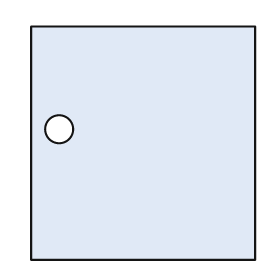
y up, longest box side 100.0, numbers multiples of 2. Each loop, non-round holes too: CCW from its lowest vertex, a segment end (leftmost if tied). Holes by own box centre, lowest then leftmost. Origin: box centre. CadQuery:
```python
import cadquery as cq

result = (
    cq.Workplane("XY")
    .moveTo(-48.0, -50.0)
    .lineTo(48.0, -50.0)
    .lineTo(48.0, 50.0)
    .lineTo(-48.0, 50.0)
    .close()
    .moveTo(-36.0, 6.0)
    .circle(6.0)
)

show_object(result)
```